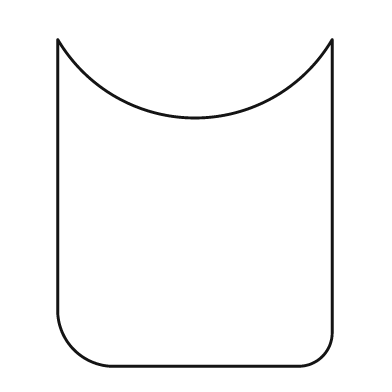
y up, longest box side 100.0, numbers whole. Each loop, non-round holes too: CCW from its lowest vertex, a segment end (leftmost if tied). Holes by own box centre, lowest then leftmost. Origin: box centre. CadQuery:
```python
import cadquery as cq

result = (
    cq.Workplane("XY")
    .moveTo(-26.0, -50.0)
    .lineTo(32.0, -50.0)
    .threePointArc((39.0, -47.0), (42.0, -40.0))
    .lineTo(42.0, 50.0)
    .threePointArc((0.0, 26.0), (-42.0, 50.0))
    .lineTo(-42.0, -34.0)
    .threePointArc((-37.0, -45.0), (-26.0, -50.0))
    .close()
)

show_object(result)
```